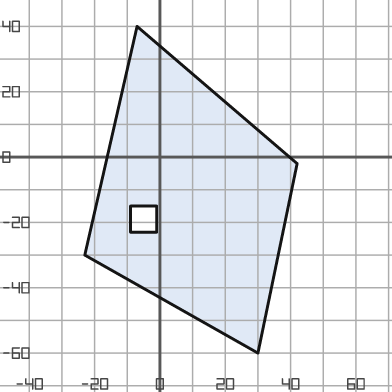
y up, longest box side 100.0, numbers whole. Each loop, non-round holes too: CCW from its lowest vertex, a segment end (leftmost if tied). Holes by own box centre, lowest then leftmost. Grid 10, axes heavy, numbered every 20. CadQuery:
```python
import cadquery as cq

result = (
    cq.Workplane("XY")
    .moveTo(30.0, -60.0)
    .lineTo(42.0, -2.0)
    .lineTo(-7.0, 40.0)
    .lineTo(-23.0, -30.0)
    .close()
    .moveTo(-9.0, -23.0)
    .lineTo(-1.0, -23.0)
    .lineTo(-1.0, -15.0)
    .lineTo(-9.0, -15.0)
    .close()
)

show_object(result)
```